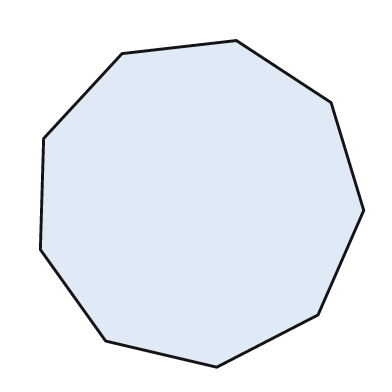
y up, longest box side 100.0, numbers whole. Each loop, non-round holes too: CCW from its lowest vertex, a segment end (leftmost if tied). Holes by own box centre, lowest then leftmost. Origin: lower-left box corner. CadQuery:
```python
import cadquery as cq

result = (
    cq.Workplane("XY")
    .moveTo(54.0, 0.0)
    .lineTo(85.0, 16.0)
    .lineTo(99.0, 48.0)
    .lineTo(89.0, 81.0)
    .lineTo(60.0, 100.0)
    .lineTo(25.0, 96.0)
    .lineTo(1.0, 70.0)
    .lineTo(0.0, 36.0)
    .lineTo(20.0, 8.0)
    .close()
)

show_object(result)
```